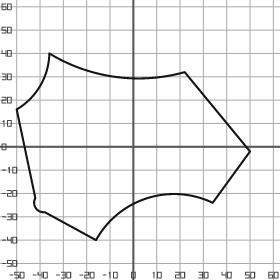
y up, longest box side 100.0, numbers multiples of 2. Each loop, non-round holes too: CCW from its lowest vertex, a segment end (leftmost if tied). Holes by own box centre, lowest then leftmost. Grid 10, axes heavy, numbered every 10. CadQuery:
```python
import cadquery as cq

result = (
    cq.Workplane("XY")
    .moveTo(-16.0, -40.0)
    .threePointArc((6.0, -22.0), (34.0, -24.0))
    .lineTo(50.0, -2.0)
    .lineTo(22.0, 32.0)
    .threePointArc((-8.0, 30.0), (-36.0, 40.0))
    .threePointArc((-40.0, 26.0), (-50.0, 16.0))
    .lineTo(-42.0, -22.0)
    .threePointArc((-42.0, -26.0), (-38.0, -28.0))
    .close()
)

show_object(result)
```